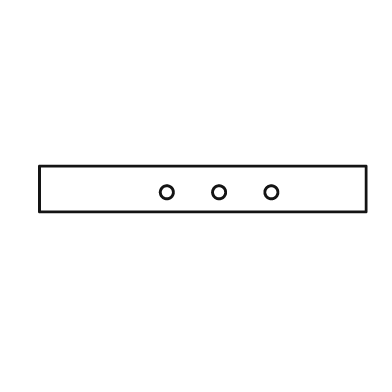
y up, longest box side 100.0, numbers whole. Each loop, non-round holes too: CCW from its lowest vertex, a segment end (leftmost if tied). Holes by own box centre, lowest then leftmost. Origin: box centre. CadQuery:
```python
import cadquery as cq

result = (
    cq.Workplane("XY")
    .moveTo(-50.0, -7.0)
    .lineTo(50.0, -7.0)
    .lineTo(50.0, 7.0)
    .lineTo(-50.0, 7.0)
    .close()
    .moveTo(-11.0, -1.0)
    .circle(2.0)
    .moveTo(5.0, -1.0)
    .circle(2.0)
    .moveTo(21.0, -1.0)
    .circle(2.0)
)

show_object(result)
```